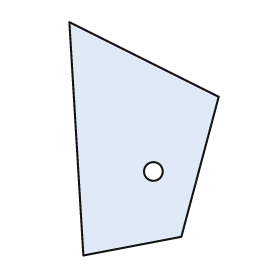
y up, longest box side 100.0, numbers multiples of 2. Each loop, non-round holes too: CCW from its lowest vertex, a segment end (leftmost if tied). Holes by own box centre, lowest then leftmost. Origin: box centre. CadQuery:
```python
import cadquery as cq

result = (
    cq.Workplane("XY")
    .moveTo(-26.0, -50.0)
    .lineTo(16.0, -42.0)
    .lineTo(32.0, 18.0)
    .lineTo(-32.0, 50.0)
    .close()
    .moveTo(4.0, -14.0)
    .circle(4.0)
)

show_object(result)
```